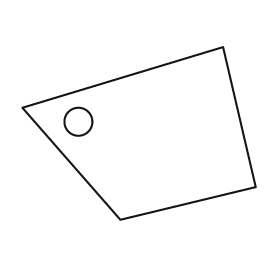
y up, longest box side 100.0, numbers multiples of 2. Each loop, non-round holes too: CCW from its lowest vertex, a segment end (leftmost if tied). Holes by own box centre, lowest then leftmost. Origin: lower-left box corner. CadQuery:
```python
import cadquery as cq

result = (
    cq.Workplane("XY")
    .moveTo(42.0, 0.0)
    .lineTo(100.0, 14.0)
    .lineTo(86.0, 74.0)
    .lineTo(0.0, 48.0)
    .close()
    .moveTo(24.0, 42.0)
    .circle(6.0)
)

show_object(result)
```